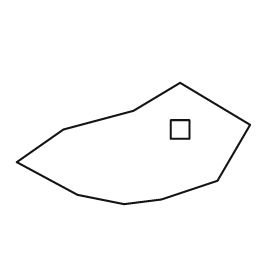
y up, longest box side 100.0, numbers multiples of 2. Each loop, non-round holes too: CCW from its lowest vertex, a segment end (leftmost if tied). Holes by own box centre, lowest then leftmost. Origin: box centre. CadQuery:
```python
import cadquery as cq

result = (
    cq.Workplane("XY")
    .moveTo(-4.0, -26.0)
    .lineTo(12.0, -24.0)
    .lineTo(36.0, -16.0)
    .lineTo(50.0, 8.0)
    .lineTo(20.0, 26.0)
    .lineTo(0.0, 14.0)
    .lineTo(-30.0, 6.0)
    .lineTo(-50.0, -8.0)
    .lineTo(-24.0, -22.0)
    .close()
    .moveTo(16.0, 2.0)
    .lineTo(24.0, 2.0)
    .lineTo(24.0, 10.0)
    .lineTo(16.0, 10.0)
    .close()
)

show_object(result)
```